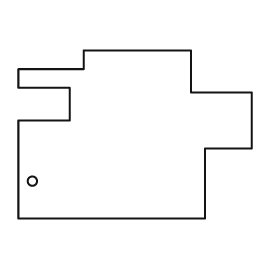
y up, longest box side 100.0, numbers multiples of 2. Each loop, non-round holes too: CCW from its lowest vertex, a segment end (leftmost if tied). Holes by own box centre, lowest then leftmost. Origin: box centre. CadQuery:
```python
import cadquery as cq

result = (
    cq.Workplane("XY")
    .moveTo(-50.0, -36.0)
    .lineTo(30.0, -36.0)
    .lineTo(30.0, -6.0)
    .lineTo(50.0, -6.0)
    .lineTo(50.0, 18.0)
    .lineTo(24.0, 18.0)
    .lineTo(24.0, 36.0)
    .lineTo(-22.0, 36.0)
    .lineTo(-22.0, 28.0)
    .lineTo(-50.0, 28.0)
    .lineTo(-50.0, 20.0)
    .lineTo(-28.0, 20.0)
    .lineTo(-28.0, 6.0)
    .lineTo(-50.0, 6.0)
    .close()
    .moveTo(-44.0, -20.0)
    .circle(2.0)
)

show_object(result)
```